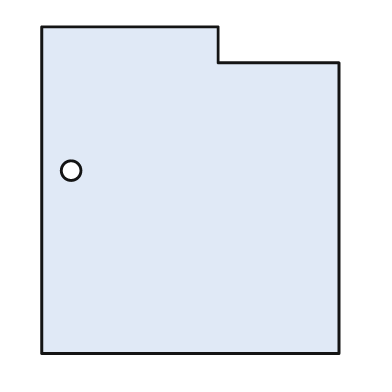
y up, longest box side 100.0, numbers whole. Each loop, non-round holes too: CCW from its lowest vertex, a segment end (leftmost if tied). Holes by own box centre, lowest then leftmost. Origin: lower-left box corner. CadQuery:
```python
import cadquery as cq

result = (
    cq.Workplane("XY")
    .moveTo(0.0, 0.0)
    .lineTo(91.0, 0.0)
    .lineTo(91.0, 89.0)
    .lineTo(54.0, 89.0)
    .lineTo(54.0, 100.0)
    .lineTo(0.0, 100.0)
    .close()
    .moveTo(9.0, 56.0)
    .circle(3.0)
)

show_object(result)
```